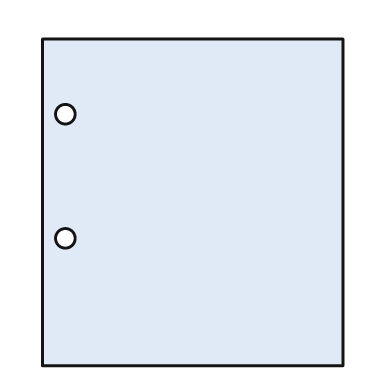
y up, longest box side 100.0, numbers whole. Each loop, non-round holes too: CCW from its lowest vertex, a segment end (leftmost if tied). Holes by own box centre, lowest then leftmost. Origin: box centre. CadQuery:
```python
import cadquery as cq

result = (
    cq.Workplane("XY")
    .moveTo(-46.0, -50.0)
    .lineTo(46.0, -50.0)
    .lineTo(46.0, 50.0)
    .lineTo(-46.0, 50.0)
    .close()
    .moveTo(-39.0, -11.0)
    .circle(3.0)
    .moveTo(-39.0, 27.0)
    .circle(3.0)
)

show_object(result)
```